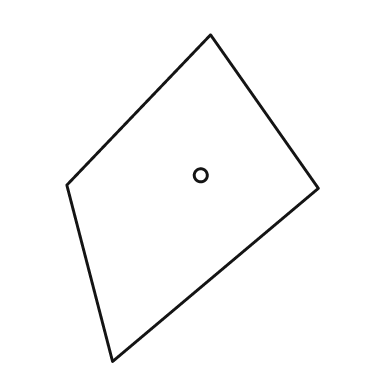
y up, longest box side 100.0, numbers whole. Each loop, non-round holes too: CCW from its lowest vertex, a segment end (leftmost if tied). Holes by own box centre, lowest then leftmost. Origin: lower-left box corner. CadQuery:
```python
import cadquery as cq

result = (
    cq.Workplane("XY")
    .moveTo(14.0, 0.0)
    .lineTo(77.0, 53.0)
    .lineTo(44.0, 100.0)
    .lineTo(0.0, 54.0)
    .close()
    .moveTo(41.0, 57.0)
    .circle(2.0)
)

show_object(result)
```